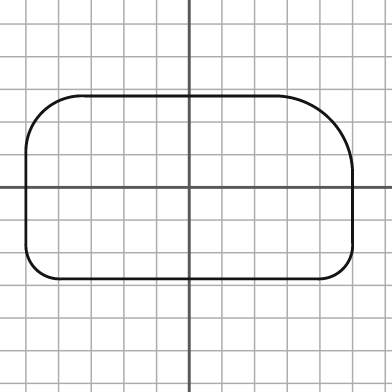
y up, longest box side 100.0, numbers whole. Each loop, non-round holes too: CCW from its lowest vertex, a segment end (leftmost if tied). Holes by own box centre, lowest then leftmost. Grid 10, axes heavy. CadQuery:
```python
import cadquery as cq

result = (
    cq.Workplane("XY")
    .moveTo(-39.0, -28.0)
    .lineTo(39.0, -28.0)
    .threePointArc((47.0, -25.0), (50.0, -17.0))
    .lineTo(50.0, 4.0)
    .threePointArc((43.0, 21.0), (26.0, 28.0))
    .lineTo(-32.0, 28.0)
    .threePointArc((-45.0, 23.0), (-50.0, 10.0))
    .lineTo(-50.0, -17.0)
    .threePointArc((-47.0, -25.0), (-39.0, -28.0))
    .close()
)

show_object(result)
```